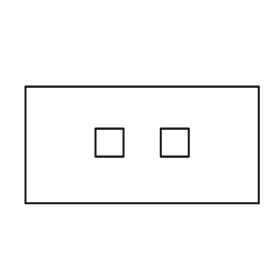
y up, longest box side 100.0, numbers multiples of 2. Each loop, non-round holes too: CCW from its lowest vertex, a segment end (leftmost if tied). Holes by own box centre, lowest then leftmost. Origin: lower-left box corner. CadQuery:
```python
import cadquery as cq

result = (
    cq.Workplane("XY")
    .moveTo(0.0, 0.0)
    .lineTo(100.0, 0.0)
    .lineTo(100.0, 50.0)
    .lineTo(0.0, 50.0)
    .close()
    .moveTo(30.0, 20.0)
    .lineTo(42.0, 20.0)
    .lineTo(42.0, 32.0)
    .lineTo(30.0, 32.0)
    .close()
    .moveTo(58.0, 20.0)
    .lineTo(70.0, 20.0)
    .lineTo(70.0, 32.0)
    .lineTo(58.0, 32.0)
    .close()
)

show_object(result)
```